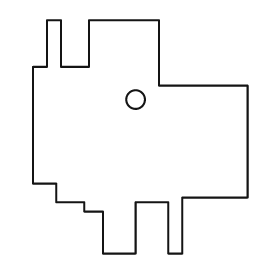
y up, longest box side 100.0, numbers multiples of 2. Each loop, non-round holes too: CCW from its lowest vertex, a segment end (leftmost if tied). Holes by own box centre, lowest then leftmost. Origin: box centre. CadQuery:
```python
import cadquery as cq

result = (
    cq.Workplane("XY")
    .moveTo(-16.0, -50.0)
    .lineTo(-2.0, -50.0)
    .lineTo(-2.0, -28.0)
    .lineTo(12.0, -28.0)
    .lineTo(12.0, -50.0)
    .lineTo(18.0, -50.0)
    .lineTo(18.0, -26.0)
    .lineTo(46.0, -26.0)
    .lineTo(46.0, 22.0)
    .lineTo(8.0, 22.0)
    .lineTo(8.0, 50.0)
    .lineTo(-22.0, 50.0)
    .lineTo(-22.0, 30.0)
    .lineTo(-34.0, 30.0)
    .lineTo(-34.0, 50.0)
    .lineTo(-40.0, 50.0)
    .lineTo(-40.0, 30.0)
    .lineTo(-46.0, 30.0)
    .lineTo(-46.0, -20.0)
    .lineTo(-36.0, -20.0)
    .lineTo(-36.0, -28.0)
    .lineTo(-24.0, -28.0)
    .lineTo(-24.0, -32.0)
    .lineTo(-16.0, -32.0)
    .close()
    .moveTo(-2.0, 16.0)
    .circle(4.0)
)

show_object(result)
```